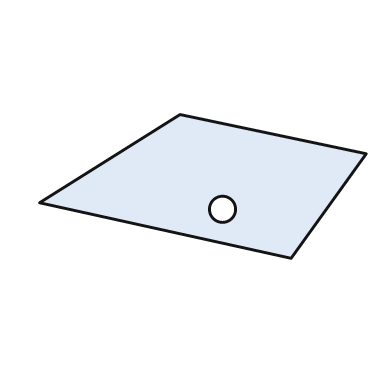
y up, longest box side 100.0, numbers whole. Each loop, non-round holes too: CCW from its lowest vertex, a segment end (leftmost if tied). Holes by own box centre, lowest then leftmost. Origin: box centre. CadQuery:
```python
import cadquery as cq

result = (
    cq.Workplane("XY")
    .moveTo(27.0, -22.0)
    .lineTo(50.0, 10.0)
    .lineTo(-7.0, 22.0)
    .lineTo(-50.0, -5.0)
    .close()
    .moveTo(6.0, -7.0)
    .circle(4.0)
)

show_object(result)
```